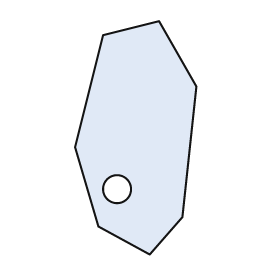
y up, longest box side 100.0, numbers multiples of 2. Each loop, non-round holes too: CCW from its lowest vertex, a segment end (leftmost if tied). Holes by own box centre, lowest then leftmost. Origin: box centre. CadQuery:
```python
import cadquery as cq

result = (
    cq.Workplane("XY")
    .moveTo(6.0, -50.0)
    .lineTo(20.0, -34.0)
    .lineTo(26.0, 22.0)
    .lineTo(10.0, 50.0)
    .lineTo(-14.0, 44.0)
    .lineTo(-26.0, -4.0)
    .lineTo(-16.0, -38.0)
    .close()
    .moveTo(-8.0, -22.0)
    .circle(6.0)
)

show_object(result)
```